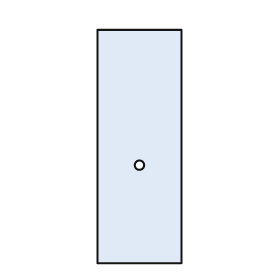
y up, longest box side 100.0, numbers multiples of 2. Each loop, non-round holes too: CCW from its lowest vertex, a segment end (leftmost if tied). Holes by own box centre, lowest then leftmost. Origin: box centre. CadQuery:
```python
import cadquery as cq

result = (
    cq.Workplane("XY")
    .moveTo(-18.0, -50.0)
    .lineTo(18.0, -50.0)
    .lineTo(18.0, 50.0)
    .lineTo(-18.0, 50.0)
    .close()
    .moveTo(0.0, -8.0)
    .circle(2.0)
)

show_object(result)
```